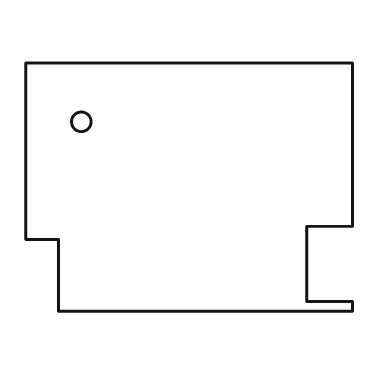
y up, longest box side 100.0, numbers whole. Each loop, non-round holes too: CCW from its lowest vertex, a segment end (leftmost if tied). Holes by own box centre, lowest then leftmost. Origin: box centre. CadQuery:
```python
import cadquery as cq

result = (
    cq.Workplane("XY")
    .moveTo(-40.0, -38.0)
    .lineTo(50.0, -38.0)
    .lineTo(50.0, -35.0)
    .lineTo(36.0, -35.0)
    .lineTo(36.0, -12.0)
    .lineTo(50.0, -12.0)
    .lineTo(50.0, 38.0)
    .lineTo(-50.0, 38.0)
    .lineTo(-50.0, -16.0)
    .lineTo(-40.0, -16.0)
    .close()
    .moveTo(-33.0, 20.0)
    .circle(3.0)
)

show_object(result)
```